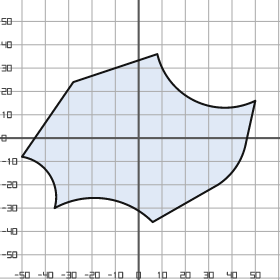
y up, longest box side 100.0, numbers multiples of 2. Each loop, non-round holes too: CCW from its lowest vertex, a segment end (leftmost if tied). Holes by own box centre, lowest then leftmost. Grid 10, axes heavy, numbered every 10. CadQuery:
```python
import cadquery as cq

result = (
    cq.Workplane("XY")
    .moveTo(6.0, -36.0)
    .lineTo(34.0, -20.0)
    .threePointArc((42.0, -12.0), (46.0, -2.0))
    .lineTo(50.0, 16.0)
    .threePointArc((24.0, 16.0), (8.0, 36.0))
    .lineTo(-28.0, 24.0)
    .lineTo(-50.0, -8.0)
    .threePointArc((-38.0, -16.0), (-36.0, -30.0))
    .threePointArc((-14.0, -26.0), (6.0, -36.0))
    .close()
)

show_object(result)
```